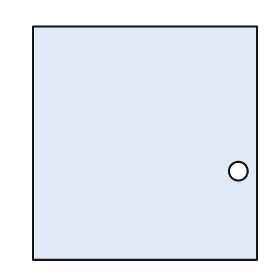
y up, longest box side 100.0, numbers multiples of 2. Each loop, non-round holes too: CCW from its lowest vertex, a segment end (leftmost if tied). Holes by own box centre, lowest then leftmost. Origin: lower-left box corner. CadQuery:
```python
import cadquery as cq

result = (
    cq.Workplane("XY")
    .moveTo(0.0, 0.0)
    .lineTo(96.0, 0.0)
    .lineTo(96.0, 100.0)
    .lineTo(0.0, 100.0)
    .close()
    .moveTo(88.0, 38.0)
    .circle(4.0)
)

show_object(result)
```